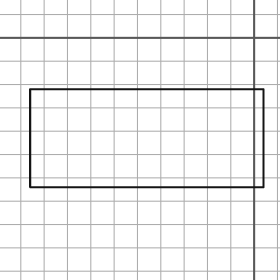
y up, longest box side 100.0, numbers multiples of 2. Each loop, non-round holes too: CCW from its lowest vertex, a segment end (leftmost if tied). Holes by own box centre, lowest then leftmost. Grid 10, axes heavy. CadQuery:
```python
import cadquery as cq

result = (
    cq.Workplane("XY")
    .moveTo(-96.0, -64.0)
    .lineTo(4.0, -64.0)
    .lineTo(4.0, -22.0)
    .lineTo(-96.0, -22.0)
    .close()
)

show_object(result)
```